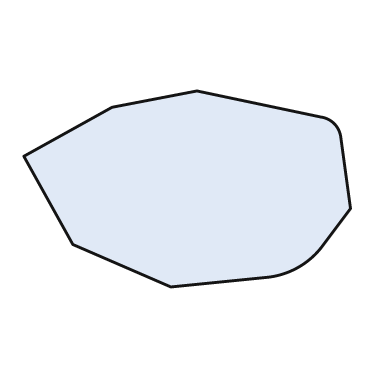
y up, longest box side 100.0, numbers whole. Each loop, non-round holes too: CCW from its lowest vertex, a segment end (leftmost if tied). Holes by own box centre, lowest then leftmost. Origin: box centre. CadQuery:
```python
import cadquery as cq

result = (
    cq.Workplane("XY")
    .moveTo(-5.0, -30.0)
    .lineTo(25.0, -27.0)
    .threePointArc((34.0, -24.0), (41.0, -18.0))
    .lineTo(50.0, -6.0)
    .lineTo(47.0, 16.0)
    .threePointArc((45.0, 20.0), (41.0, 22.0))
    .lineTo(3.0, 30.0)
    .lineTo(-23.0, 25.0)
    .lineTo(-50.0, 10.0)
    .lineTo(-35.0, -17.0)
    .close()
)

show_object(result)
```